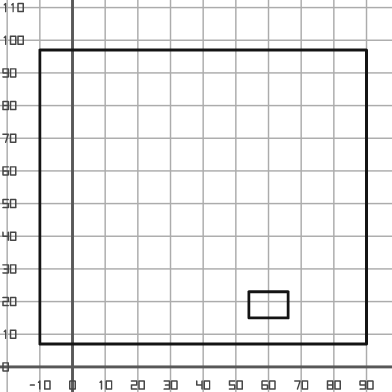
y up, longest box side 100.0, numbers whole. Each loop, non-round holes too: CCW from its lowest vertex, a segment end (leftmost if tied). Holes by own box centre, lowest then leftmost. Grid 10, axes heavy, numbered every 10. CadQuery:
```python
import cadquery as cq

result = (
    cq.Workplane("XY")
    .moveTo(-10.0, 7.0)
    .lineTo(90.0, 7.0)
    .lineTo(90.0, 97.0)
    .lineTo(-10.0, 97.0)
    .close()
    .moveTo(54.0, 15.0)
    .lineTo(66.0, 15.0)
    .lineTo(66.0, 23.0)
    .lineTo(54.0, 23.0)
    .close()
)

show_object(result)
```